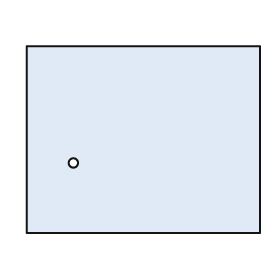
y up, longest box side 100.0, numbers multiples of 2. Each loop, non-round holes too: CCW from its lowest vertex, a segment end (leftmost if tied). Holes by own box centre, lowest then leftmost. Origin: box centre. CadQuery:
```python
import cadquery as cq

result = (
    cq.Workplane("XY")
    .moveTo(-50.0, -40.0)
    .lineTo(50.0, -40.0)
    .lineTo(50.0, 40.0)
    .lineTo(-50.0, 40.0)
    .close()
    .moveTo(-30.0, -10.0)
    .circle(2.0)
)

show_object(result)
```